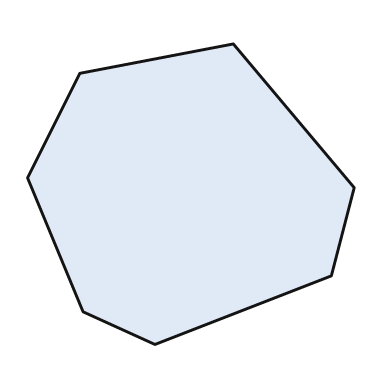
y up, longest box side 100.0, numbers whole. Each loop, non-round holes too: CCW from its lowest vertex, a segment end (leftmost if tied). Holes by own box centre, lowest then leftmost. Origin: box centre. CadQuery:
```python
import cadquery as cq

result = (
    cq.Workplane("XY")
    .moveTo(-11.0, -46.0)
    .lineTo(43.0, -25.0)
    .lineTo(50.0, 2.0)
    .lineTo(13.0, 46.0)
    .lineTo(-34.0, 37.0)
    .lineTo(-50.0, 5.0)
    .lineTo(-33.0, -36.0)
    .close()
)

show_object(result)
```